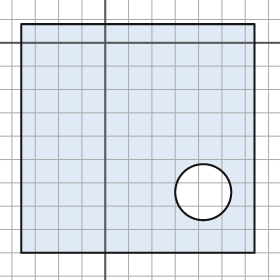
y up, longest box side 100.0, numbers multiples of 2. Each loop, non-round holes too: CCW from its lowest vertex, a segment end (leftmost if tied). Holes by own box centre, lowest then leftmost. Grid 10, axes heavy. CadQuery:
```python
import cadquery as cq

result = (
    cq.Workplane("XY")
    .moveTo(-36.0, -90.0)
    .lineTo(64.0, -90.0)
    .lineTo(64.0, 8.0)
    .lineTo(-36.0, 8.0)
    .close()
    .moveTo(42.0, -64.0)
    .circle(12.0)
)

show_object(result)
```